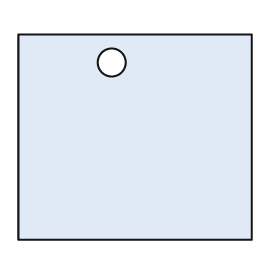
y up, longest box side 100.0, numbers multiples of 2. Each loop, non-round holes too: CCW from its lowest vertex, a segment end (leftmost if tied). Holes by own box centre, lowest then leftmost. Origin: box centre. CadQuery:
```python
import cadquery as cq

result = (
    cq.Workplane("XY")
    .moveTo(-50.0, -44.0)
    .lineTo(50.0, -44.0)
    .lineTo(50.0, 44.0)
    .lineTo(-50.0, 44.0)
    .close()
    .moveTo(-10.0, 32.0)
    .circle(6.0)
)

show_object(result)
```